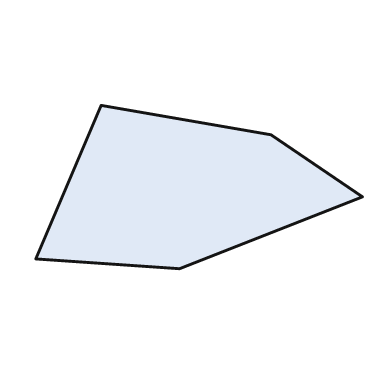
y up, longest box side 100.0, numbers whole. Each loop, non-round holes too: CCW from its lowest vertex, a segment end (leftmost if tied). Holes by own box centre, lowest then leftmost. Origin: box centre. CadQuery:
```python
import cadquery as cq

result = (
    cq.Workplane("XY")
    .moveTo(-6.0, -25.0)
    .lineTo(50.0, -3.0)
    .lineTo(22.0, 16.0)
    .lineTo(-30.0, 25.0)
    .lineTo(-50.0, -22.0)
    .close()
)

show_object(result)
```